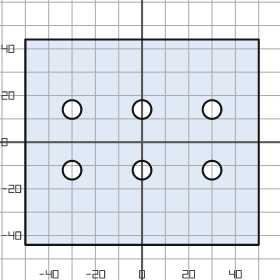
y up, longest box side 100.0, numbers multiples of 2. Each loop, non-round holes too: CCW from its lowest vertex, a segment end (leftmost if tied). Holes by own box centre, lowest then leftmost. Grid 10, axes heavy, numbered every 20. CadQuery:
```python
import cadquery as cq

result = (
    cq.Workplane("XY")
    .moveTo(-50.0, -44.0)
    .lineTo(50.0, -44.0)
    .lineTo(50.0, 44.0)
    .lineTo(-50.0, 44.0)
    .close()
    .moveTo(-30.0, -12.0)
    .circle(4.0)
    .moveTo(0.0, -12.0)
    .circle(4.0)
    .moveTo(30.0, -12.0)
    .circle(4.0)
    .moveTo(-30.0, 14.0)
    .circle(4.0)
    .moveTo(0.0, 14.0)
    .circle(4.0)
    .moveTo(30.0, 14.0)
    .circle(4.0)
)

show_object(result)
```